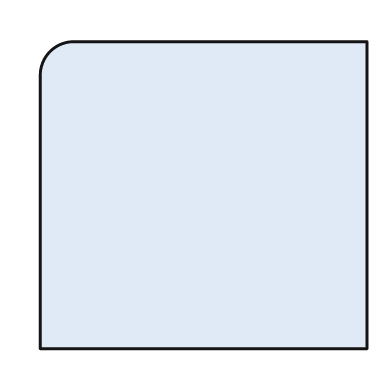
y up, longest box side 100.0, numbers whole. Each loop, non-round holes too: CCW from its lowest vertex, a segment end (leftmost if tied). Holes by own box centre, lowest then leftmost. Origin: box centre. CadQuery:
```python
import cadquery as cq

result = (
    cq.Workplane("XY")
    .moveTo(-50.0, -47.0)
    .lineTo(50.0, -47.0)
    .lineTo(50.0, 47.0)
    .lineTo(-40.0, 47.0)
    .threePointArc((-47.0, 44.0), (-50.0, 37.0))
    .close()
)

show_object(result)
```